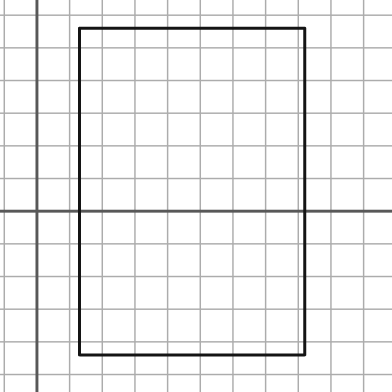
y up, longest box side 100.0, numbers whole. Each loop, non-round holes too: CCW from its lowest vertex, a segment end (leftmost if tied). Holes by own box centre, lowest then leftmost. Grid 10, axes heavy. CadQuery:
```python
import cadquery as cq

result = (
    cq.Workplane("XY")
    .moveTo(13.0, -44.0)
    .lineTo(82.0, -44.0)
    .lineTo(82.0, 56.0)
    .lineTo(13.0, 56.0)
    .close()
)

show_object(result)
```